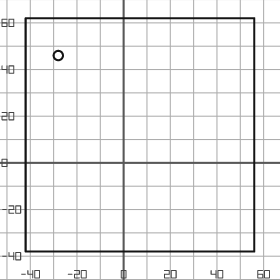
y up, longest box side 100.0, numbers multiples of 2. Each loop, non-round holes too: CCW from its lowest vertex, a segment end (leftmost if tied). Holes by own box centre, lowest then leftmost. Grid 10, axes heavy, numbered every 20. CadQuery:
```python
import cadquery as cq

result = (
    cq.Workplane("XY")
    .moveTo(-42.0, -38.0)
    .lineTo(56.0, -38.0)
    .lineTo(56.0, 62.0)
    .lineTo(-42.0, 62.0)
    .close()
    .moveTo(-28.0, 46.0)
    .circle(2.0)
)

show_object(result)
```